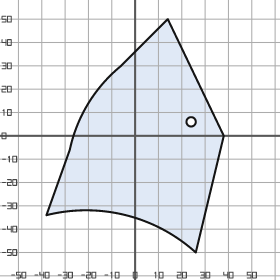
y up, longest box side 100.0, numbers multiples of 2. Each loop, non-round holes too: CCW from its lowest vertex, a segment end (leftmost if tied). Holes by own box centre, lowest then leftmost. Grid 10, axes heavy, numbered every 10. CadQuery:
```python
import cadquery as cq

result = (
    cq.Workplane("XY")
    .moveTo(26.0, -50.0)
    .lineTo(38.0, 0.0)
    .lineTo(14.0, 50.0)
    .lineTo(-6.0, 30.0)
    .threePointArc((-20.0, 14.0), (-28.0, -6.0))
    .lineTo(-38.0, -34.0)
    .threePointArc((-4.0, -34.0), (26.0, -50.0))
    .close()
    .moveTo(24.0, 6.0)
    .circle(2.0)
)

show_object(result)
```